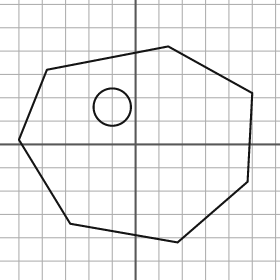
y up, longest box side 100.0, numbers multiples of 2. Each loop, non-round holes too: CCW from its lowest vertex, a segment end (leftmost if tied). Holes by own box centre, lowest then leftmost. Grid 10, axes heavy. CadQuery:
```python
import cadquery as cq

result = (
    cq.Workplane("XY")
    .moveTo(18.0, -42.0)
    .lineTo(48.0, -16.0)
    .lineTo(50.0, 22.0)
    .lineTo(14.0, 42.0)
    .lineTo(-38.0, 32.0)
    .lineTo(-50.0, 2.0)
    .lineTo(-28.0, -34.0)
    .close()
    .moveTo(-10.0, 16.0)
    .circle(8.0)
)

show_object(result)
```